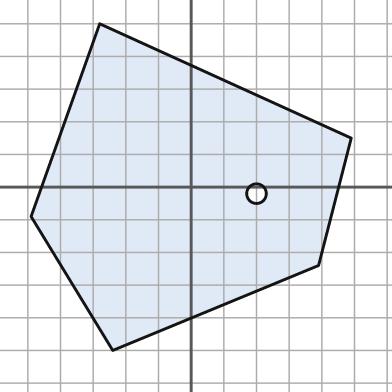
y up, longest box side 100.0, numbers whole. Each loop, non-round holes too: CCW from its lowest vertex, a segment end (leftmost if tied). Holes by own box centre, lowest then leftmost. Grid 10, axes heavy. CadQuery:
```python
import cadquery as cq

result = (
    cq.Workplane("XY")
    .moveTo(-24.0, -50.0)
    .lineTo(39.0, -24.0)
    .lineTo(49.0, 15.0)
    .lineTo(-28.0, 50.0)
    .lineTo(-49.0, -9.0)
    .close()
    .moveTo(20.0, -2.0)
    .circle(3.0)
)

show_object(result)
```